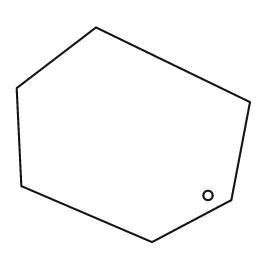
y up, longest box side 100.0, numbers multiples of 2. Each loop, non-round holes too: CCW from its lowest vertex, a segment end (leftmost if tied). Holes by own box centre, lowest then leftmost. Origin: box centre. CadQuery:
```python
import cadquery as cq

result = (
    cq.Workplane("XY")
    .moveTo(8.0, -46.0)
    .lineTo(42.0, -28.0)
    .lineTo(50.0, 14.0)
    .lineTo(-16.0, 46.0)
    .lineTo(-50.0, 20.0)
    .lineTo(-48.0, -22.0)
    .close()
    .moveTo(32.0, -26.0)
    .circle(2.0)
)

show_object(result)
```